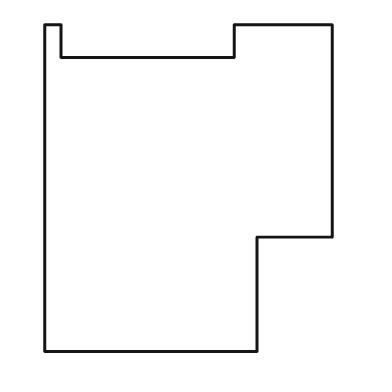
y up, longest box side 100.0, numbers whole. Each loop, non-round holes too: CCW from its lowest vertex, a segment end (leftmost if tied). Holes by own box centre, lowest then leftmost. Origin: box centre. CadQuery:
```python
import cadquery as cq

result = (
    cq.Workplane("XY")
    .moveTo(-44.0, -50.0)
    .lineTo(21.0, -50.0)
    .lineTo(21.0, -15.0)
    .lineTo(44.0, -15.0)
    .lineTo(44.0, 50.0)
    .lineTo(14.0, 50.0)
    .lineTo(14.0, 40.0)
    .lineTo(-39.0, 40.0)
    .lineTo(-39.0, 50.0)
    .lineTo(-44.0, 50.0)
    .close()
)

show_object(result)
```